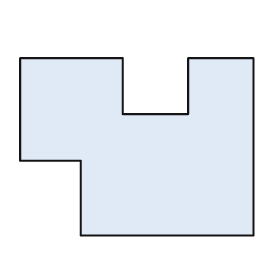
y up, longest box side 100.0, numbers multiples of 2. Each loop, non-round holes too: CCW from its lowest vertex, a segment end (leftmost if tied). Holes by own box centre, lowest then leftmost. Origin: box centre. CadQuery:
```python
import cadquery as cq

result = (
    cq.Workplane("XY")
    .moveTo(-24.0, -38.0)
    .lineTo(50.0, -38.0)
    .lineTo(50.0, 38.0)
    .lineTo(22.0, 38.0)
    .lineTo(22.0, 14.0)
    .lineTo(-6.0, 14.0)
    .lineTo(-6.0, 38.0)
    .lineTo(-50.0, 38.0)
    .lineTo(-50.0, -6.0)
    .lineTo(-24.0, -6.0)
    .close()
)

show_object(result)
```